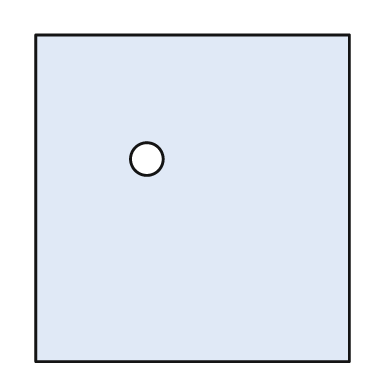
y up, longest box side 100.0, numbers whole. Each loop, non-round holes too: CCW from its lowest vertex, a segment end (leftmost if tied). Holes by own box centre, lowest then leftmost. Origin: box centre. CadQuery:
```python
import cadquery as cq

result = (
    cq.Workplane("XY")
    .moveTo(-48.0, -50.0)
    .lineTo(48.0, -50.0)
    .lineTo(48.0, 50.0)
    .lineTo(-48.0, 50.0)
    .close()
    .moveTo(-14.0, 12.0)
    .circle(5.0)
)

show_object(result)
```